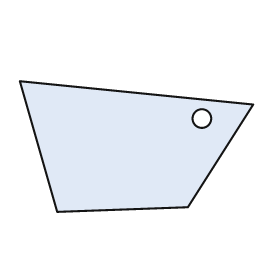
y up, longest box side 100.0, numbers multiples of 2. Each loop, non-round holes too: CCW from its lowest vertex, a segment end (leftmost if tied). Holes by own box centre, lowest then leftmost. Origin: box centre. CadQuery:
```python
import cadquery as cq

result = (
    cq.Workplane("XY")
    .moveTo(-34.0, -28.0)
    .lineTo(22.0, -26.0)
    .lineTo(50.0, 18.0)
    .lineTo(-50.0, 28.0)
    .close()
    .moveTo(28.0, 12.0)
    .circle(4.0)
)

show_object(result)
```